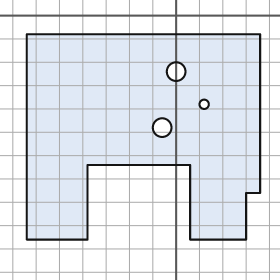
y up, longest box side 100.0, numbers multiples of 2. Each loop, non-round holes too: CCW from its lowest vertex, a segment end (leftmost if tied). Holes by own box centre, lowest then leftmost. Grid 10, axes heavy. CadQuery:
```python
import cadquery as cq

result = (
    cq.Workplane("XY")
    .moveTo(-64.0, -96.0)
    .lineTo(-38.0, -96.0)
    .lineTo(-38.0, -64.0)
    .lineTo(6.0, -64.0)
    .lineTo(6.0, -96.0)
    .lineTo(30.0, -96.0)
    .lineTo(30.0, -76.0)
    .lineTo(36.0, -76.0)
    .lineTo(36.0, -8.0)
    .lineTo(-64.0, -8.0)
    .close()
    .moveTo(-6.0, -48.0)
    .circle(4.0)
    .moveTo(12.0, -38.0)
    .circle(2.0)
    .moveTo(0.0, -24.0)
    .circle(4.0)
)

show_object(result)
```